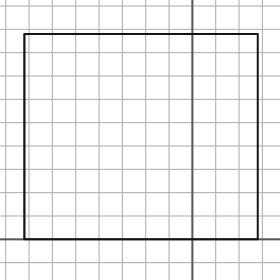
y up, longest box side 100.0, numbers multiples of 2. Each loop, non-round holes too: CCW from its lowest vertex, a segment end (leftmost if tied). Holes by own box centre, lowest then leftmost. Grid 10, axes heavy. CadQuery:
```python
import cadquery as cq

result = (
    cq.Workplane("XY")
    .moveTo(-72.0, 0.0)
    .lineTo(28.0, 0.0)
    .lineTo(28.0, 88.0)
    .lineTo(-72.0, 88.0)
    .close()
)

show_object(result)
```